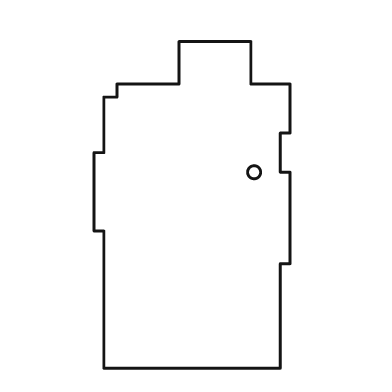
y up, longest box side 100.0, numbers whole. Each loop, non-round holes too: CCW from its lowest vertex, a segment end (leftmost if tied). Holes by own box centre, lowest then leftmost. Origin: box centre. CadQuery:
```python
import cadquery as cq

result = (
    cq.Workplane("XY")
    .moveTo(-27.0, -50.0)
    .lineTo(27.0, -50.0)
    .lineTo(27.0, -18.0)
    .lineTo(30.0, -18.0)
    .lineTo(30.0, 10.0)
    .lineTo(27.0, 10.0)
    .lineTo(27.0, 22.0)
    .lineTo(30.0, 22.0)
    .lineTo(30.0, 37.0)
    .lineTo(18.0, 37.0)
    .lineTo(18.0, 50.0)
    .lineTo(-4.0, 50.0)
    .lineTo(-4.0, 37.0)
    .lineTo(-23.0, 37.0)
    .lineTo(-23.0, 33.0)
    .lineTo(-27.0, 33.0)
    .lineTo(-27.0, 16.0)
    .lineTo(-30.0, 16.0)
    .lineTo(-30.0, -8.0)
    .lineTo(-27.0, -8.0)
    .close()
    .moveTo(19.0, 10.0)
    .circle(2.0)
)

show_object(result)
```